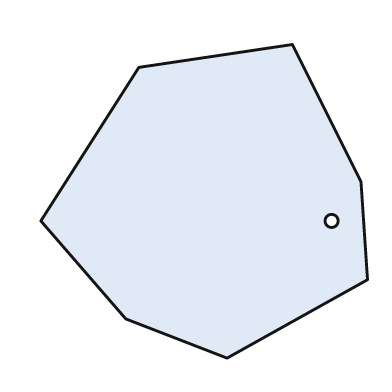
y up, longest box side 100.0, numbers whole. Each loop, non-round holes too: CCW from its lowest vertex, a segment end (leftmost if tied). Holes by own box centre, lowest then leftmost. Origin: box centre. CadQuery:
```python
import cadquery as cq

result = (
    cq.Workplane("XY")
    .moveTo(7.0, -48.0)
    .lineTo(50.0, -24.0)
    .lineTo(48.0, 6.0)
    .lineTo(27.0, 48.0)
    .lineTo(-20.0, 41.0)
    .lineTo(-50.0, -6.0)
    .lineTo(-24.0, -36.0)
    .close()
    .moveTo(39.0, -6.0)
    .circle(2.0)
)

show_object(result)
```